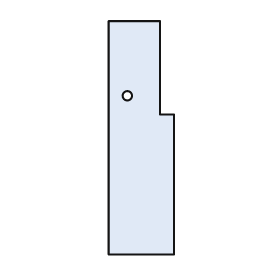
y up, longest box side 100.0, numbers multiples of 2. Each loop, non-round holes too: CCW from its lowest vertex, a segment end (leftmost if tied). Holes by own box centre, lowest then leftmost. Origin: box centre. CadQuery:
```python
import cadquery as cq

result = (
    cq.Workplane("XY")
    .moveTo(-14.0, -50.0)
    .lineTo(14.0, -50.0)
    .lineTo(14.0, 10.0)
    .lineTo(8.0, 10.0)
    .lineTo(8.0, 50.0)
    .lineTo(-14.0, 50.0)
    .close()
    .moveTo(-6.0, 18.0)
    .circle(2.0)
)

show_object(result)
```